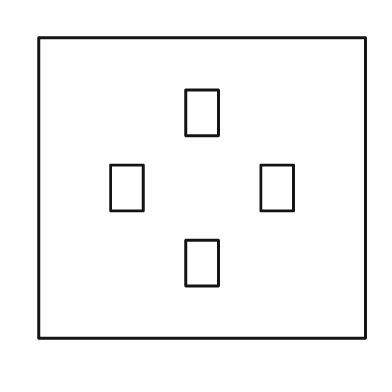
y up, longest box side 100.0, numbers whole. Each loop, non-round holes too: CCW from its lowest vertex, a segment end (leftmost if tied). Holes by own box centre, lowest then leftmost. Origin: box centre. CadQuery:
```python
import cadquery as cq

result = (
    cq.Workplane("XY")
    .moveTo(-50.0, -46.0)
    .lineTo(50.0, -46.0)
    .lineTo(50.0, 46.0)
    .lineTo(-50.0, 46.0)
    .close()
    .moveTo(-5.0, -30.0)
    .lineTo(5.0, -30.0)
    .lineTo(5.0, -16.0)
    .lineTo(-5.0, -16.0)
    .close()
    .moveTo(-28.0, -7.0)
    .lineTo(-18.0, -7.0)
    .lineTo(-18.0, 7.0)
    .lineTo(-28.0, 7.0)
    .close()
    .moveTo(18.0, -7.0)
    .lineTo(28.0, -7.0)
    .lineTo(28.0, 7.0)
    .lineTo(18.0, 7.0)
    .close()
    .moveTo(-5.0, 16.0)
    .lineTo(5.0, 16.0)
    .lineTo(5.0, 30.0)
    .lineTo(-5.0, 30.0)
    .close()
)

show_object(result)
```